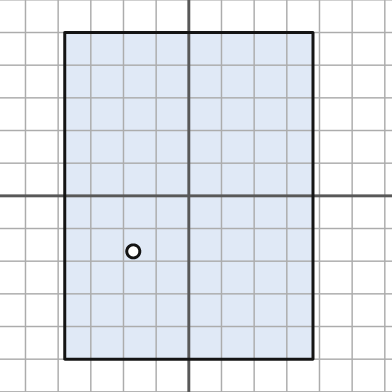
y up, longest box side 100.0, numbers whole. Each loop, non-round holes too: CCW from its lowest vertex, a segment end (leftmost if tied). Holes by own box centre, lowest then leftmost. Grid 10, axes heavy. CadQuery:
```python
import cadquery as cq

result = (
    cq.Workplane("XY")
    .moveTo(-38.0, -50.0)
    .lineTo(38.0, -50.0)
    .lineTo(38.0, 50.0)
    .lineTo(-38.0, 50.0)
    .close()
    .moveTo(-17.0, -17.0)
    .circle(2.0)
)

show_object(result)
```